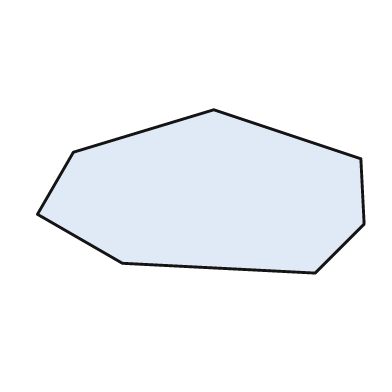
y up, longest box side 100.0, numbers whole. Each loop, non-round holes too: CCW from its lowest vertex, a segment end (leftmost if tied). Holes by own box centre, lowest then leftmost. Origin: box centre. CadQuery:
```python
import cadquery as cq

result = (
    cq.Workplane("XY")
    .moveTo(35.0, -25.0)
    .lineTo(50.0, -10.0)
    .lineTo(49.0, 10.0)
    .lineTo(4.0, 25.0)
    .lineTo(-39.0, 12.0)
    .lineTo(-50.0, -7.0)
    .lineTo(-24.0, -22.0)
    .close()
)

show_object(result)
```